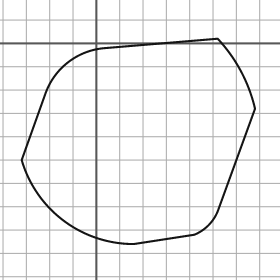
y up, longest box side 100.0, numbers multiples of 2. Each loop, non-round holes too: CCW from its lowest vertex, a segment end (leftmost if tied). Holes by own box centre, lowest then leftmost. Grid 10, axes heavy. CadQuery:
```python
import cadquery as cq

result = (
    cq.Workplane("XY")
    .moveTo(16.0, -86.0)
    .lineTo(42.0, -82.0)
    .threePointArc((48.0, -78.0), (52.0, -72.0))
    .lineTo(68.0, -28.0)
    .threePointArc((62.0, -12.0), (52.0, 2.0))
    .lineTo(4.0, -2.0)
    .threePointArc((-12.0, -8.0), (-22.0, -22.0))
    .lineTo(-32.0, -50.0)
    .threePointArc((-14.0, -76.0), (16.0, -86.0))
    .close()
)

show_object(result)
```